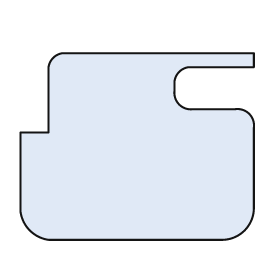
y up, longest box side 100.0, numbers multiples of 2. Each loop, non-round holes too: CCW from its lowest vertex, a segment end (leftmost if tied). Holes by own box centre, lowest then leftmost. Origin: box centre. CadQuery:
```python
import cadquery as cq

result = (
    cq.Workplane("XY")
    .moveTo(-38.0, -40.0)
    .lineTo(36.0, -40.0)
    .threePointArc((46.0, -36.0), (50.0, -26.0))
    .lineTo(50.0, 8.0)
    .threePointArc((48.0, 14.0), (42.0, 16.0))
    .lineTo(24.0, 16.0)
    .threePointArc((18.0, 18.0), (16.0, 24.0))
    .lineTo(16.0, 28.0)
    .threePointArc((18.0, 32.0), (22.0, 34.0))
    .lineTo(50.0, 34.0)
    .lineTo(50.0, 40.0)
    .lineTo(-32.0, 40.0)
    .threePointArc((-36.0, 38.0), (-38.0, 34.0))
    .lineTo(-38.0, 6.0)
    .lineTo(-50.0, 6.0)
    .lineTo(-50.0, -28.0)
    .threePointArc((-46.0, -36.0), (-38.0, -40.0))
    .close()
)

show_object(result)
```